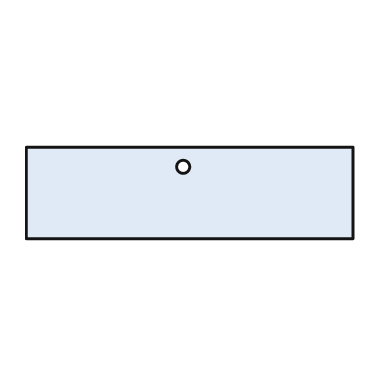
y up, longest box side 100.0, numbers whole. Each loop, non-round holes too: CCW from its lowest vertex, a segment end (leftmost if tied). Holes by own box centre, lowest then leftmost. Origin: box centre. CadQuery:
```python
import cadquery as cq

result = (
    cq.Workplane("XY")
    .moveTo(-50.0, -14.0)
    .lineTo(50.0, -14.0)
    .lineTo(50.0, 14.0)
    .lineTo(-50.0, 14.0)
    .close()
    .moveTo(-2.0, 8.0)
    .circle(2.0)
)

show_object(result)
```